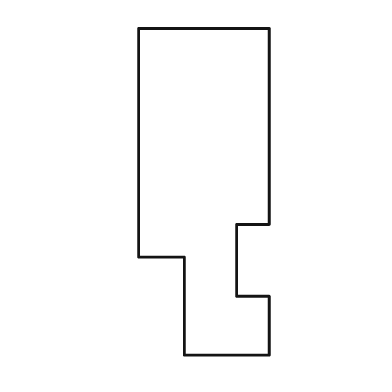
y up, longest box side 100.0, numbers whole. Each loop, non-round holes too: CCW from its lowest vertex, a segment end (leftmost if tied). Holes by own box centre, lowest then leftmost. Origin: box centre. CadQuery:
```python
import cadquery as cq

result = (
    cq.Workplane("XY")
    .moveTo(-6.0, -50.0)
    .lineTo(20.0, -50.0)
    .lineTo(20.0, -32.0)
    .lineTo(10.0, -32.0)
    .lineTo(10.0, -10.0)
    .lineTo(20.0, -10.0)
    .lineTo(20.0, 50.0)
    .lineTo(-20.0, 50.0)
    .lineTo(-20.0, -20.0)
    .lineTo(-6.0, -20.0)
    .close()
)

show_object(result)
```